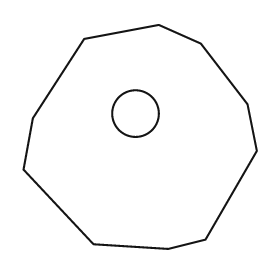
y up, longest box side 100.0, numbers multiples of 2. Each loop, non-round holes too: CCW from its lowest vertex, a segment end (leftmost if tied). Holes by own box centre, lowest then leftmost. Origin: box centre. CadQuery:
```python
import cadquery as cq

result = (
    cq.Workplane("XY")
    .moveTo(12.0, -48.0)
    .lineTo(28.0, -44.0)
    .lineTo(50.0, -6.0)
    .lineTo(46.0, 14.0)
    .lineTo(26.0, 40.0)
    .lineTo(8.0, 48.0)
    .lineTo(-24.0, 42.0)
    .lineTo(-46.0, 8.0)
    .lineTo(-50.0, -14.0)
    .lineTo(-20.0, -46.0)
    .close()
    .moveTo(-2.0, 10.0)
    .circle(10.0)
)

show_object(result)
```